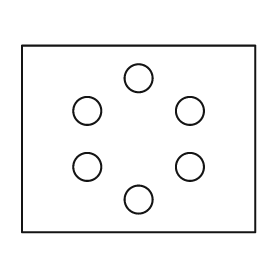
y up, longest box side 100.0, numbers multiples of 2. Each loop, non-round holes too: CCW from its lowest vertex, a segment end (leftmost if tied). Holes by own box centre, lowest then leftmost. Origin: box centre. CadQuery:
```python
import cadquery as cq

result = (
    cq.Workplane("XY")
    .moveTo(-50.0, -40.0)
    .lineTo(50.0, -40.0)
    .lineTo(50.0, 40.0)
    .lineTo(-50.0, 40.0)
    .close()
    .moveTo(0.0, -26.0)
    .circle(6.0)
    .moveTo(-22.0, -12.0)
    .circle(6.0)
    .moveTo(22.0, -12.0)
    .circle(6.0)
    .moveTo(-22.0, 12.0)
    .circle(6.0)
    .moveTo(22.0, 12.0)
    .circle(6.0)
    .moveTo(0.0, 26.0)
    .circle(6.0)
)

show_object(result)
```